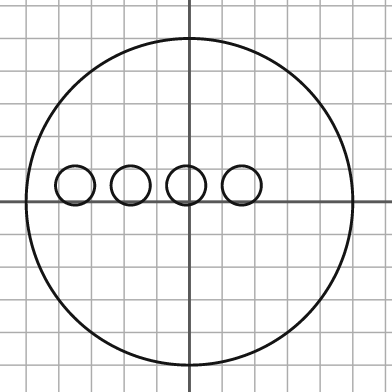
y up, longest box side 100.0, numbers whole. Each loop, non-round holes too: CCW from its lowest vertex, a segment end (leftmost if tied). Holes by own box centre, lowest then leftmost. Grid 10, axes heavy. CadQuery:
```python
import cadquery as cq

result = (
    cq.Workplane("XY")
    .moveTo(0.0, 0.0)
    .circle(50.0)
    .moveTo(-35.0, 5.0)
    .circle(6.0)
    .moveTo(-18.0, 5.0)
    .circle(6.0)
    .moveTo(-1.0, 5.0)
    .circle(6.0)
    .moveTo(16.0, 5.0)
    .circle(6.0)
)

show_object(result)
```